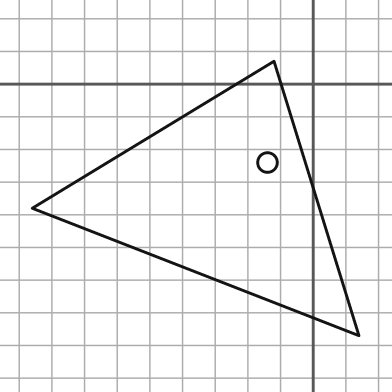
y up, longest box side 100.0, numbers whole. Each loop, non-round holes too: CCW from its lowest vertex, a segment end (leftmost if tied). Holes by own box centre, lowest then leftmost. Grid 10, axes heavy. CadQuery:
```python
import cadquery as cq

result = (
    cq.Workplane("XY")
    .moveTo(14.0, -77.0)
    .lineTo(-12.0, 7.0)
    .lineTo(-86.0, -38.0)
    .close()
    .moveTo(-14.0, -24.0)
    .circle(3.0)
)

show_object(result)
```